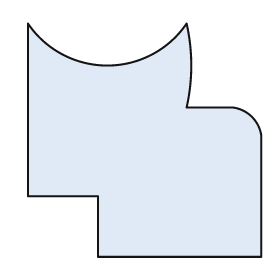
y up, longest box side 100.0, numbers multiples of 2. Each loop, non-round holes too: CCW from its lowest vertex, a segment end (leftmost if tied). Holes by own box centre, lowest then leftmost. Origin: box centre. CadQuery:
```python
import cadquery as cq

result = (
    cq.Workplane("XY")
    .moveTo(-20.0, -50.0)
    .lineTo(50.0, -50.0)
    .lineTo(50.0, 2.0)
    .threePointArc((46.0, 10.0), (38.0, 14.0))
    .lineTo(18.0, 14.0)
    .threePointArc((20.0, 32.0), (18.0, 50.0))
    .threePointArc((-16.0, 32.0), (-50.0, 50.0))
    .lineTo(-50.0, -24.0)
    .lineTo(-20.0, -24.0)
    .close()
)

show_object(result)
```